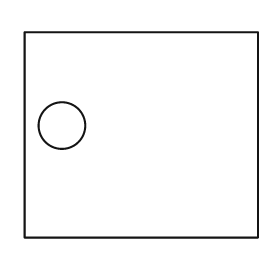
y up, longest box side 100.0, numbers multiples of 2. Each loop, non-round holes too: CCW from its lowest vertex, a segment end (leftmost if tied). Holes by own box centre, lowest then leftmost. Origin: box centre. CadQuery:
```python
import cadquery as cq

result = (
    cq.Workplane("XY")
    .moveTo(-50.0, -44.0)
    .lineTo(50.0, -44.0)
    .lineTo(50.0, 44.0)
    .lineTo(-50.0, 44.0)
    .close()
    .moveTo(-34.0, 4.0)
    .circle(10.0)
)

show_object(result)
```